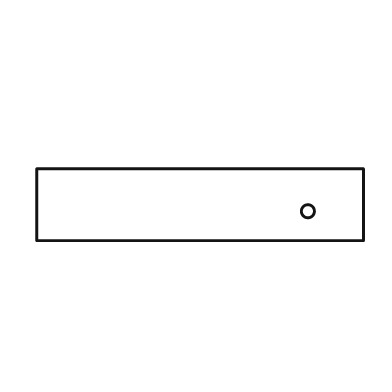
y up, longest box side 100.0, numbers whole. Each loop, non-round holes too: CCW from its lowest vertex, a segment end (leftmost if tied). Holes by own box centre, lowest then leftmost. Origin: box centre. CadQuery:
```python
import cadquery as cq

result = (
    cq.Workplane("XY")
    .moveTo(-50.0, -11.0)
    .lineTo(50.0, -11.0)
    .lineTo(50.0, 11.0)
    .lineTo(-50.0, 11.0)
    .close()
    .moveTo(33.0, -2.0)
    .circle(2.0)
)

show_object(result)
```